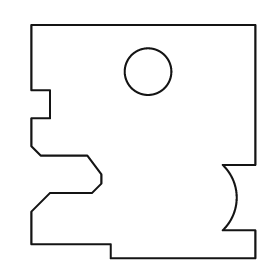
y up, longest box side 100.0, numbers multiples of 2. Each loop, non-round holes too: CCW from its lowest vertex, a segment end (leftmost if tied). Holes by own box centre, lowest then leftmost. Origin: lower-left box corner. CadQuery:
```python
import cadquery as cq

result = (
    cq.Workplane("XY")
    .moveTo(34.0, 0.0)
    .lineTo(96.0, 0.0)
    .lineTo(96.0, 12.0)
    .lineTo(82.0, 12.0)
    .threePointArc((88.0, 26.0), (82.0, 40.0))
    .lineTo(96.0, 40.0)
    .lineTo(96.0, 100.0)
    .lineTo(0.0, 100.0)
    .lineTo(0.0, 72.0)
    .lineTo(8.0, 72.0)
    .lineTo(8.0, 60.0)
    .lineTo(0.0, 60.0)
    .lineTo(0.0, 48.0)
    .lineTo(4.0, 44.0)
    .lineTo(24.0, 44.0)
    .lineTo(30.0, 36.0)
    .lineTo(30.0, 32.0)
    .lineTo(26.0, 28.0)
    .lineTo(8.0, 28.0)
    .lineTo(0.0, 20.0)
    .lineTo(0.0, 6.0)
    .lineTo(34.0, 6.0)
    .close()
    .moveTo(50.0, 80.0)
    .circle(10.0)
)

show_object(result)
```